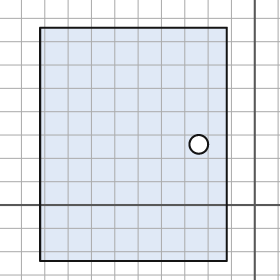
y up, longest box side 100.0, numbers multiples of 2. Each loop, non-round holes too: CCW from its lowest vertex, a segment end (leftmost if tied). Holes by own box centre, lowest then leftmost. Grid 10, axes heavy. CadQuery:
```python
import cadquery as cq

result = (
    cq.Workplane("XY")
    .moveTo(-92.0, -24.0)
    .lineTo(-12.0, -24.0)
    .lineTo(-12.0, 76.0)
    .lineTo(-92.0, 76.0)
    .close()
    .moveTo(-24.0, 26.0)
    .circle(4.0)
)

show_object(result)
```